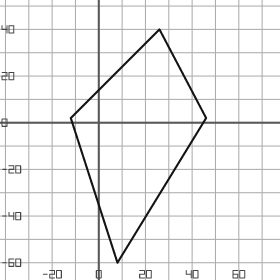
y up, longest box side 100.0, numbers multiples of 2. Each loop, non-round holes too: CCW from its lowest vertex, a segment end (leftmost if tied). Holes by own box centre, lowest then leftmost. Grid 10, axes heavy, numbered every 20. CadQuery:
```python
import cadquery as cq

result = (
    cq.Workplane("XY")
    .moveTo(8.0, -60.0)
    .lineTo(46.0, 2.0)
    .lineTo(26.0, 40.0)
    .lineTo(-12.0, 2.0)
    .close()
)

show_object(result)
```